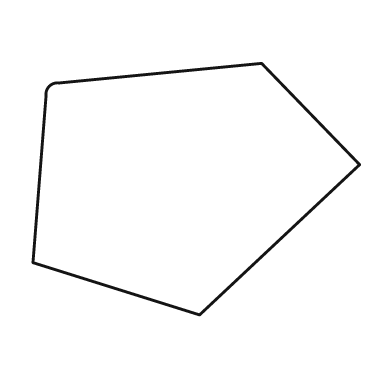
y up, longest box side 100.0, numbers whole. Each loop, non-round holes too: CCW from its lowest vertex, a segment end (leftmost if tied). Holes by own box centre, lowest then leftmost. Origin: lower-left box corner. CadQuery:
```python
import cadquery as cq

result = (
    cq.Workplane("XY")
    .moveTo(51.0, 0.0)
    .lineTo(100.0, 46.0)
    .lineTo(70.0, 77.0)
    .lineTo(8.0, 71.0)
    .threePointArc((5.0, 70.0), (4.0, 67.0))
    .lineTo(0.0, 16.0)
    .close()
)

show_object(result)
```